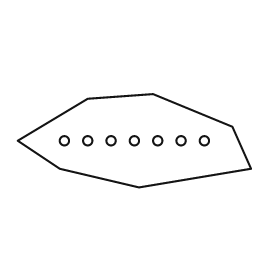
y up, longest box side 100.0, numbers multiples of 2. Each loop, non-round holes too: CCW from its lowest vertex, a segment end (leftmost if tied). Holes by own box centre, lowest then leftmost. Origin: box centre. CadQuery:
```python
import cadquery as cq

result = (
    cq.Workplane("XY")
    .moveTo(2.0, -20.0)
    .lineTo(50.0, -12.0)
    .lineTo(42.0, 6.0)
    .lineTo(8.0, 20.0)
    .lineTo(-20.0, 18.0)
    .lineTo(-50.0, 0.0)
    .lineTo(-32.0, -12.0)
    .close()
    .moveTo(-30.0, 0.0)
    .circle(2.0)
    .moveTo(-20.0, 0.0)
    .circle(2.0)
    .moveTo(-10.0, 0.0)
    .circle(2.0)
    .moveTo(0.0, 0.0)
    .circle(2.0)
    .moveTo(10.0, 0.0)
    .circle(2.0)
    .moveTo(20.0, 0.0)
    .circle(2.0)
    .moveTo(30.0, 0.0)
    .circle(2.0)
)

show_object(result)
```